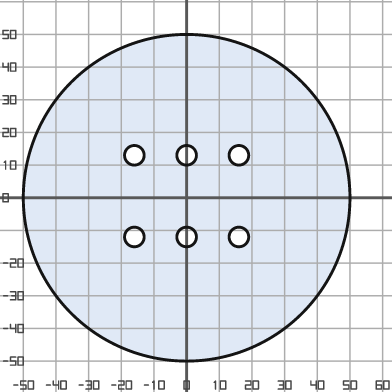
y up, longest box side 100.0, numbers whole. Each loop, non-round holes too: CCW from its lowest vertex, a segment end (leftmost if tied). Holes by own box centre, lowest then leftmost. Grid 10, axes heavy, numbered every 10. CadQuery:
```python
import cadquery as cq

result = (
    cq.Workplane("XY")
    .moveTo(0.0, 0.0)
    .circle(50.0)
    .moveTo(-16.0, -12.0)
    .circle(3.0)
    .moveTo(0.0, -12.0)
    .circle(3.0)
    .moveTo(16.0, -12.0)
    .circle(3.0)
    .moveTo(-16.0, 13.0)
    .circle(3.0)
    .moveTo(0.0, 13.0)
    .circle(3.0)
    .moveTo(16.0, 13.0)
    .circle(3.0)
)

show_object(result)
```